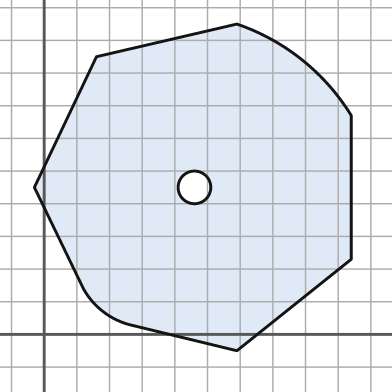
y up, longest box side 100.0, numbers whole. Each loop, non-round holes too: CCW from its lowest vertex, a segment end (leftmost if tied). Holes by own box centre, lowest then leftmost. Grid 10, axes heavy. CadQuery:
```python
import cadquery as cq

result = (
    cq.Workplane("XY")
    .moveTo(59.0, -5.0)
    .lineTo(94.0, 23.0)
    .lineTo(94.0, 67.0)
    .threePointArc((79.0, 84.0), (59.0, 95.0))
    .lineTo(16.0, 85.0)
    .lineTo(-3.0, 45.0)
    .lineTo(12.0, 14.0)
    .threePointArc((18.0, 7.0), (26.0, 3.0))
    .close()
    .moveTo(46.0, 45.0)
    .circle(5.0)
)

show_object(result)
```